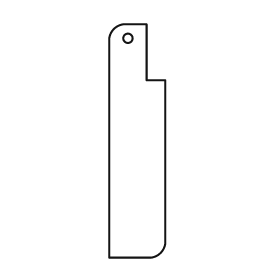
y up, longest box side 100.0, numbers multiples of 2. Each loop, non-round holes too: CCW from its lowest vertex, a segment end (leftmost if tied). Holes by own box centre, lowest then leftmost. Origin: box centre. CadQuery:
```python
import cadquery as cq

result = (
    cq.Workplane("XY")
    .moveTo(-12.0, -50.0)
    .lineTo(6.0, -50.0)
    .threePointArc((10.0, -48.0), (12.0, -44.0))
    .lineTo(12.0, 26.0)
    .lineTo(4.0, 26.0)
    .lineTo(4.0, 50.0)
    .lineTo(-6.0, 50.0)
    .threePointArc((-10.0, 48.0), (-12.0, 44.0))
    .close()
    .moveTo(-4.0, 44.0)
    .circle(2.0)
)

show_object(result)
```